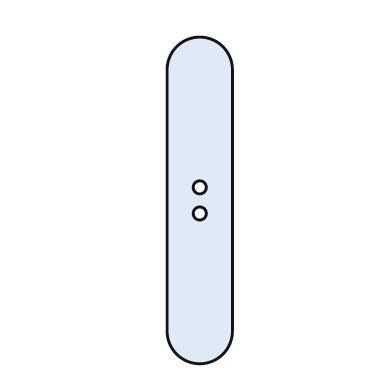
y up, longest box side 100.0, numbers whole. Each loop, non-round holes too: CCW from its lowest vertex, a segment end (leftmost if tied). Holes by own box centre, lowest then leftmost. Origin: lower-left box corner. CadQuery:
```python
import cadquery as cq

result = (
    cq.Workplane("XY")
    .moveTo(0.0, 10.0)
    .threePointArc((10.0, 0.0), (20.0, 10.0))
    .lineTo(20.0, 90.0)
    .threePointArc((10.0, 100.0), (0.0, 90.0))
    .close()
    .moveTo(10.0, 46.0)
    .circle(2.0)
    .moveTo(10.0, 54.0)
    .circle(2.0)
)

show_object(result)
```